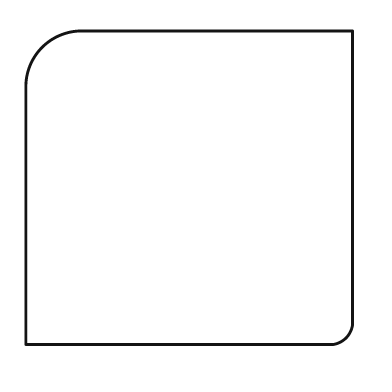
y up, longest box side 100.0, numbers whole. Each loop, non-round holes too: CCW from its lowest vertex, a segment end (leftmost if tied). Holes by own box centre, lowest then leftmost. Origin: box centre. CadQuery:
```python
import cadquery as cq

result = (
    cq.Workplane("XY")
    .moveTo(-50.0, -48.0)
    .lineTo(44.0, -48.0)
    .threePointArc((48.0, -46.0), (50.0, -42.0))
    .lineTo(50.0, 48.0)
    .lineTo(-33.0, 48.0)
    .threePointArc((-45.0, 43.0), (-50.0, 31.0))
    .close()
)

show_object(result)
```